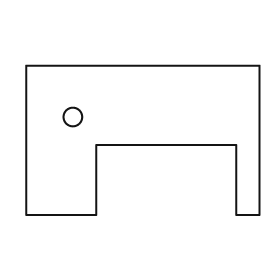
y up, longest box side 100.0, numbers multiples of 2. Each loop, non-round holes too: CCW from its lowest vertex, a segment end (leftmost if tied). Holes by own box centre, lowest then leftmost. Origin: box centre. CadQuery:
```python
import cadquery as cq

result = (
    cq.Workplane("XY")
    .moveTo(-50.0, -32.0)
    .lineTo(-20.0, -32.0)
    .lineTo(-20.0, -2.0)
    .lineTo(40.0, -2.0)
    .lineTo(40.0, -32.0)
    .lineTo(50.0, -32.0)
    .lineTo(50.0, 32.0)
    .lineTo(-50.0, 32.0)
    .close()
    .moveTo(-30.0, 10.0)
    .circle(4.0)
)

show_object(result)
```